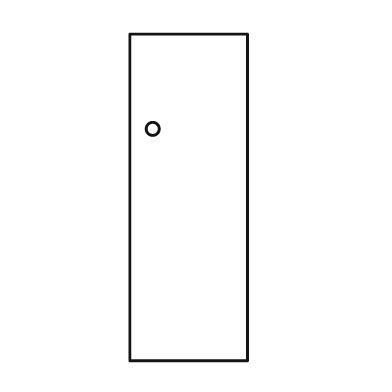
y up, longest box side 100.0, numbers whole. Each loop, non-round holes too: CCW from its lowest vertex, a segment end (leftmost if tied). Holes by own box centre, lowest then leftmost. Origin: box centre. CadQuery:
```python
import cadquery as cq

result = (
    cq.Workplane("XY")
    .moveTo(-18.0, -50.0)
    .lineTo(18.0, -50.0)
    .lineTo(18.0, 50.0)
    .lineTo(-18.0, 50.0)
    .close()
    .moveTo(-11.0, 21.0)
    .circle(2.0)
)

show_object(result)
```